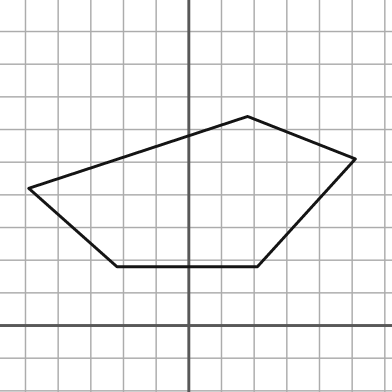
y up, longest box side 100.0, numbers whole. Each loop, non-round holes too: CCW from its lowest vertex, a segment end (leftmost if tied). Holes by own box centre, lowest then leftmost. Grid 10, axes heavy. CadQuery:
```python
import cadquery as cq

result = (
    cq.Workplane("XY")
    .moveTo(-22.0, 18.0)
    .lineTo(21.0, 18.0)
    .lineTo(51.0, 51.0)
    .lineTo(18.0, 64.0)
    .lineTo(-49.0, 42.0)
    .close()
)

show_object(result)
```